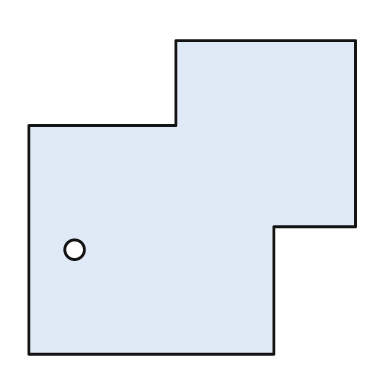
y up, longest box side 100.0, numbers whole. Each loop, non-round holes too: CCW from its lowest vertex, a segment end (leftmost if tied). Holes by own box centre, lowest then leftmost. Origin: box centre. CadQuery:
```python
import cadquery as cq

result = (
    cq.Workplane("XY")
    .moveTo(-50.0, -48.0)
    .lineTo(25.0, -48.0)
    .lineTo(25.0, -9.0)
    .lineTo(50.0, -9.0)
    .lineTo(50.0, 48.0)
    .lineTo(-5.0, 48.0)
    .lineTo(-5.0, 22.0)
    .lineTo(-50.0, 22.0)
    .close()
    .moveTo(-36.0, -16.0)
    .circle(3.0)
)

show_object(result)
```